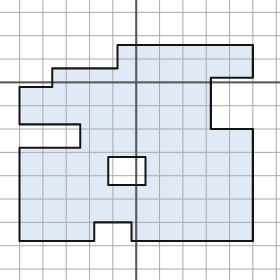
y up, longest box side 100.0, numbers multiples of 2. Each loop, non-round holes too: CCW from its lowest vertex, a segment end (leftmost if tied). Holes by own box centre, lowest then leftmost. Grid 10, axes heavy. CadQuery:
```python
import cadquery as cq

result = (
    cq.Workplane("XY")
    .moveTo(-50.0, -68.0)
    .lineTo(-18.0, -68.0)
    .lineTo(-18.0, -60.0)
    .lineTo(-2.0, -60.0)
    .lineTo(-2.0, -68.0)
    .lineTo(50.0, -68.0)
    .lineTo(50.0, -20.0)
    .lineTo(32.0, -20.0)
    .lineTo(32.0, 2.0)
    .lineTo(50.0, 2.0)
    .lineTo(50.0, 16.0)
    .lineTo(-8.0, 16.0)
    .lineTo(-8.0, 6.0)
    .lineTo(-36.0, 6.0)
    .lineTo(-36.0, -2.0)
    .lineTo(-50.0, -2.0)
    .lineTo(-50.0, -18.0)
    .lineTo(-24.0, -18.0)
    .lineTo(-24.0, -28.0)
    .lineTo(-50.0, -28.0)
    .close()
    .moveTo(-12.0, -44.0)
    .lineTo(4.0, -44.0)
    .lineTo(4.0, -32.0)
    .lineTo(-12.0, -32.0)
    .close()
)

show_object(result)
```